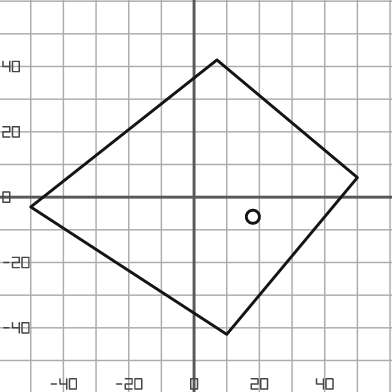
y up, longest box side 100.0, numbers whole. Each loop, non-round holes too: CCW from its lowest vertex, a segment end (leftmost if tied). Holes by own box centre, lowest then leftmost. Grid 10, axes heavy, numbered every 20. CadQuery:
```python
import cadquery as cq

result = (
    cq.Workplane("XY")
    .moveTo(10.0, -42.0)
    .lineTo(50.0, 6.0)
    .lineTo(7.0, 42.0)
    .lineTo(-50.0, -3.0)
    .close()
    .moveTo(18.0, -6.0)
    .circle(2.0)
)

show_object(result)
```